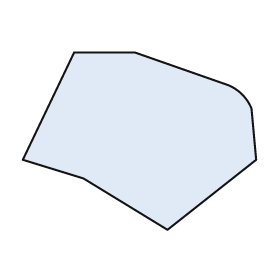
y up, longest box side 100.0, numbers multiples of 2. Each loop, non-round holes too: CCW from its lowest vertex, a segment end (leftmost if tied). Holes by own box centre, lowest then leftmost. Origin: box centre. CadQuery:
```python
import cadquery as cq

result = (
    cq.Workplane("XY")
    .moveTo(12.0, -38.0)
    .lineTo(50.0, -8.0)
    .lineTo(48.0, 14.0)
    .threePointArc((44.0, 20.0), (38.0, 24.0))
    .lineTo(-2.0, 38.0)
    .lineTo(-28.0, 38.0)
    .lineTo(-50.0, -8.0)
    .lineTo(-24.0, -16.0)
    .close()
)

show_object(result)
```